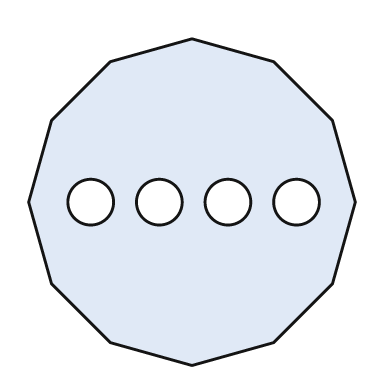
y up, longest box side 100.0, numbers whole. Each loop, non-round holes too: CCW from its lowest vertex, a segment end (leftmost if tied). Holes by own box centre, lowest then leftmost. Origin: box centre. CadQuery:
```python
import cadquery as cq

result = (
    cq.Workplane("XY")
    .moveTo(0.0, -50.0)
    .lineTo(25.0, -43.0)
    .lineTo(43.0, -25.0)
    .lineTo(50.0, 0.0)
    .lineTo(43.0, 25.0)
    .lineTo(25.0, 43.0)
    .lineTo(0.0, 50.0)
    .lineTo(-25.0, 43.0)
    .lineTo(-43.0, 25.0)
    .lineTo(-50.0, 0.0)
    .lineTo(-43.0, -25.0)
    .lineTo(-25.0, -43.0)
    .close()
    .moveTo(-31.0, 0.0)
    .circle(7.0)
    .moveTo(-10.0, 0.0)
    .circle(7.0)
    .moveTo(11.0, 0.0)
    .circle(7.0)
    .moveTo(32.0, 0.0)
    .circle(7.0)
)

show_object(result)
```